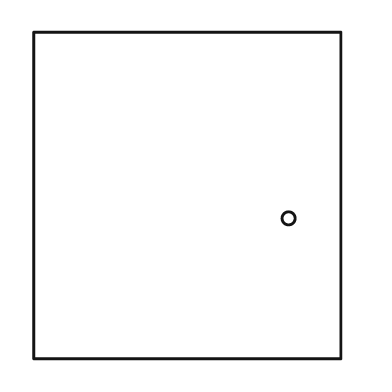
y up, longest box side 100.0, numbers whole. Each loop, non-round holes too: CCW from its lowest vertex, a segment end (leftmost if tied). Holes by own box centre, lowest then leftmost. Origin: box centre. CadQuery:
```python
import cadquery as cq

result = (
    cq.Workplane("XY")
    .moveTo(-47.0, -50.0)
    .lineTo(47.0, -50.0)
    .lineTo(47.0, 50.0)
    .lineTo(-47.0, 50.0)
    .close()
    .moveTo(31.0, -7.0)
    .circle(2.0)
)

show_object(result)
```